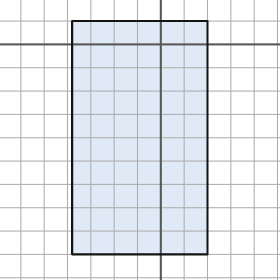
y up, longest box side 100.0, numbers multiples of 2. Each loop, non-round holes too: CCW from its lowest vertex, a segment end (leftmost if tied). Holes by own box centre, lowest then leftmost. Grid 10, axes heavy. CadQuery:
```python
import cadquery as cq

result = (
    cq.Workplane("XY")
    .moveTo(-38.0, -90.0)
    .lineTo(20.0, -90.0)
    .lineTo(20.0, 10.0)
    .lineTo(-38.0, 10.0)
    .close()
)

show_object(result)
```